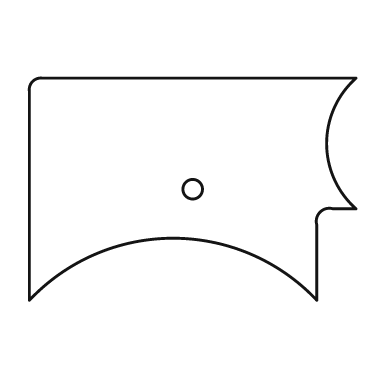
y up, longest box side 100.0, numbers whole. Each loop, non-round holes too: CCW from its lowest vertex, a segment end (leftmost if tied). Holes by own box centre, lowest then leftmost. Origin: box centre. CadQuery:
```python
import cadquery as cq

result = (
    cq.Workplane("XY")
    .moveTo(-50.0, -34.0)
    .threePointArc((-6.0, -15.0), (38.0, -34.0))
    .lineTo(38.0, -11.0)
    .threePointArc((39.0, -7.0), (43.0, -6.0))
    .lineTo(50.0, -6.0)
    .threePointArc((41.0, 14.0), (50.0, 34.0))
    .lineTo(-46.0, 34.0)
    .threePointArc((-49.0, 33.0), (-50.0, 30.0))
    .close()
    .moveTo(0.0, 0.0)
    .circle(3.0)
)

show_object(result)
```